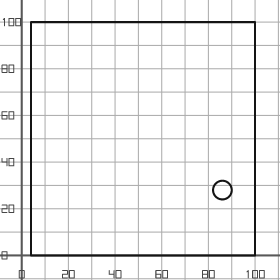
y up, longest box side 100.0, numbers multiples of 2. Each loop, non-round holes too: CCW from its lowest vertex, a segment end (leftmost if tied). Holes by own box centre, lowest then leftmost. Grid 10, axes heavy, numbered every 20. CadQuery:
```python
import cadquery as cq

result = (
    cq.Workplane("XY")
    .moveTo(4.0, 0.0)
    .lineTo(100.0, 0.0)
    .lineTo(100.0, 100.0)
    .lineTo(4.0, 100.0)
    .close()
    .moveTo(86.0, 28.0)
    .circle(4.0)
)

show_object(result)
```